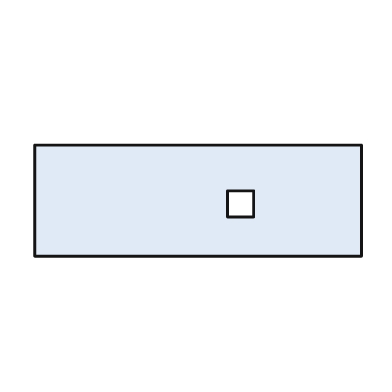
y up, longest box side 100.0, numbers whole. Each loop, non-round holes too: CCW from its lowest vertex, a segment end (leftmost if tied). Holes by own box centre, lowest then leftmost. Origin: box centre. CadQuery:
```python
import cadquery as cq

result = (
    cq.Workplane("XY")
    .moveTo(-50.0, -17.0)
    .lineTo(50.0, -17.0)
    .lineTo(50.0, 17.0)
    .lineTo(-50.0, 17.0)
    .close()
    .moveTo(9.0, -5.0)
    .lineTo(17.0, -5.0)
    .lineTo(17.0, 3.0)
    .lineTo(9.0, 3.0)
    .close()
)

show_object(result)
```